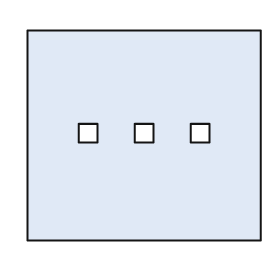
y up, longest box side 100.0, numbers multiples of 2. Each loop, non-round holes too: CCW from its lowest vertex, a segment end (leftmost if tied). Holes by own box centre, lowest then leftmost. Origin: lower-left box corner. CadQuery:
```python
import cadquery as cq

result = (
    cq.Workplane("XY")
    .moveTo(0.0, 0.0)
    .lineTo(100.0, 0.0)
    .lineTo(100.0, 90.0)
    .lineTo(0.0, 90.0)
    .close()
    .moveTo(22.0, 42.0)
    .lineTo(30.0, 42.0)
    .lineTo(30.0, 50.0)
    .lineTo(22.0, 50.0)
    .close()
    .moveTo(46.0, 42.0)
    .lineTo(54.0, 42.0)
    .lineTo(54.0, 50.0)
    .lineTo(46.0, 50.0)
    .close()
    .moveTo(70.0, 42.0)
    .lineTo(78.0, 42.0)
    .lineTo(78.0, 50.0)
    .lineTo(70.0, 50.0)
    .close()
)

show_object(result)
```